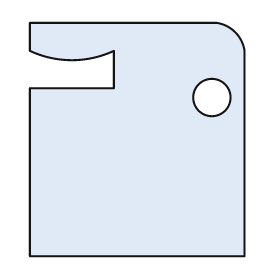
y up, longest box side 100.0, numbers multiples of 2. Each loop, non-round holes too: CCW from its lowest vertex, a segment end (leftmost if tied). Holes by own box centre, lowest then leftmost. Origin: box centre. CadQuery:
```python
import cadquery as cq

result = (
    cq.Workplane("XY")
    .moveTo(-46.0, -50.0)
    .lineTo(46.0, -50.0)
    .lineTo(46.0, 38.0)
    .threePointArc((42.0, 46.0), (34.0, 50.0))
    .lineTo(-46.0, 50.0)
    .lineTo(-46.0, 38.0)
    .threePointArc((-28.0, 34.0), (-10.0, 38.0))
    .lineTo(-10.0, 22.0)
    .lineTo(-46.0, 22.0)
    .close()
    .moveTo(32.0, 18.0)
    .circle(8.0)
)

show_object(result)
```